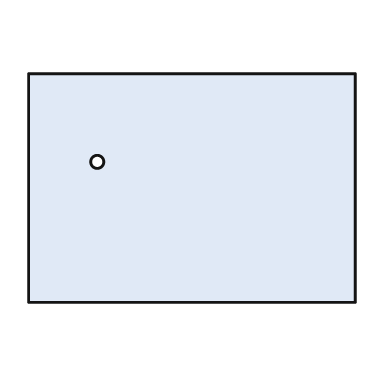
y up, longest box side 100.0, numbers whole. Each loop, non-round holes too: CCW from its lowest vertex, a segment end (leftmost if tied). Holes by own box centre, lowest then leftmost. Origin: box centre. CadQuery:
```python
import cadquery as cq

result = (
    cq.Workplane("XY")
    .moveTo(-50.0, -35.0)
    .lineTo(50.0, -35.0)
    .lineTo(50.0, 35.0)
    .lineTo(-50.0, 35.0)
    .close()
    .moveTo(-29.0, 8.0)
    .circle(2.0)
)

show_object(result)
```